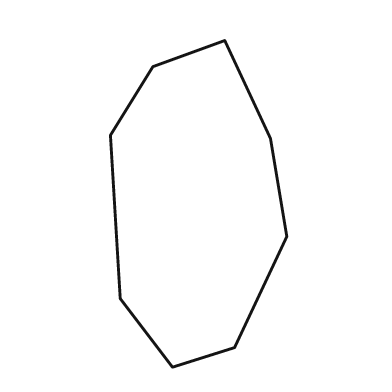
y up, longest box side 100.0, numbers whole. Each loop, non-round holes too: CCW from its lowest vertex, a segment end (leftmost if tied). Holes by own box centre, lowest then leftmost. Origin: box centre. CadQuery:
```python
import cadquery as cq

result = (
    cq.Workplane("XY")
    .moveTo(-8.0, -50.0)
    .lineTo(11.0, -44.0)
    .lineTo(27.0, -10.0)
    .lineTo(22.0, 20.0)
    .lineTo(8.0, 50.0)
    .lineTo(-14.0, 42.0)
    .lineTo(-27.0, 21.0)
    .lineTo(-24.0, -29.0)
    .close()
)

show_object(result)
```